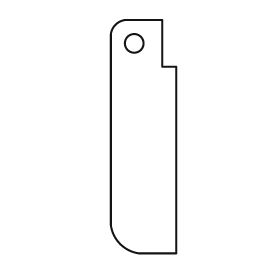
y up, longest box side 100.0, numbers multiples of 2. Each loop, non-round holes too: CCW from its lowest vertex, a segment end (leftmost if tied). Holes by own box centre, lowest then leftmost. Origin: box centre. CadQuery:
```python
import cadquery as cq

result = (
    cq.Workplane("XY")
    .moveTo(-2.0, -50.0)
    .lineTo(14.0, -50.0)
    .lineTo(14.0, 30.0)
    .lineTo(8.0, 30.0)
    .lineTo(8.0, 50.0)
    .lineTo(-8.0, 50.0)
    .threePointArc((-12.0, 48.0), (-14.0, 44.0))
    .lineTo(-14.0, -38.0)
    .threePointArc((-10.0, -46.0), (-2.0, -50.0))
    .close()
    .moveTo(-4.0, 40.0)
    .circle(4.0)
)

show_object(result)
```